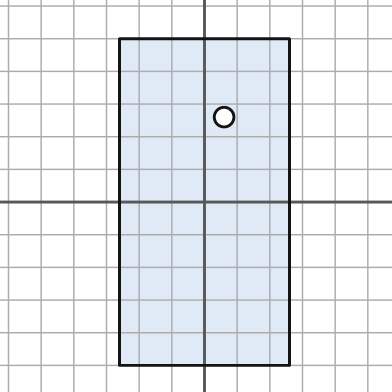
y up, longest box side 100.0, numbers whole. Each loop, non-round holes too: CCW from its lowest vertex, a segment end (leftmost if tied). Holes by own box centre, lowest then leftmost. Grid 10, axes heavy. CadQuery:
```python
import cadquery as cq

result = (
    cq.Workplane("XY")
    .moveTo(-26.0, -50.0)
    .lineTo(26.0, -50.0)
    .lineTo(26.0, 50.0)
    .lineTo(-26.0, 50.0)
    .close()
    .moveTo(6.0, 26.0)
    .circle(3.0)
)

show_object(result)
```